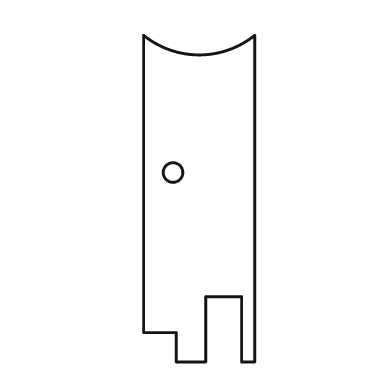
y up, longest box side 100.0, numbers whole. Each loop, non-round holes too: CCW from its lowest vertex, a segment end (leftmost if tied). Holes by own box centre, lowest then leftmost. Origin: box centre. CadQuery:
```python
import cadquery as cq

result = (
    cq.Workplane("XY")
    .moveTo(-7.0, -50.0)
    .lineTo(2.0, -50.0)
    .lineTo(2.0, -30.0)
    .lineTo(13.0, -30.0)
    .lineTo(13.0, -50.0)
    .lineTo(17.0, -50.0)
    .lineTo(17.0, 50.0)
    .threePointArc((0.0, 44.0), (-17.0, 50.0))
    .lineTo(-17.0, -41.0)
    .lineTo(-7.0, -41.0)
    .close()
    .moveTo(-8.0, 8.0)
    .circle(3.0)
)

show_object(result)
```